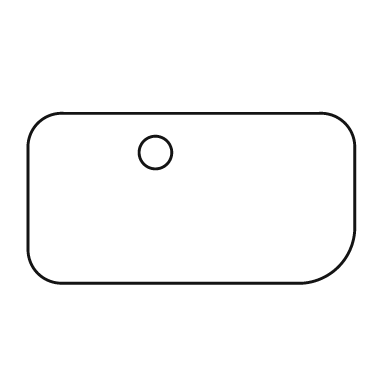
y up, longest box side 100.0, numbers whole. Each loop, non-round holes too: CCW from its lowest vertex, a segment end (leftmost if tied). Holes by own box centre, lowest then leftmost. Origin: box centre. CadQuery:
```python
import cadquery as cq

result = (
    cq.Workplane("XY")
    .moveTo(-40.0, -26.0)
    .lineTo(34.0, -26.0)
    .threePointArc((45.0, -21.0), (50.0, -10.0))
    .lineTo(50.0, 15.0)
    .threePointArc((47.0, 23.0), (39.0, 26.0))
    .lineTo(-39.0, 26.0)
    .threePointArc((-47.0, 23.0), (-50.0, 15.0))
    .lineTo(-50.0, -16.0)
    .threePointArc((-47.0, -23.0), (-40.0, -26.0))
    .close()
    .moveTo(-11.0, 14.0)
    .circle(5.0)
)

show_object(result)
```